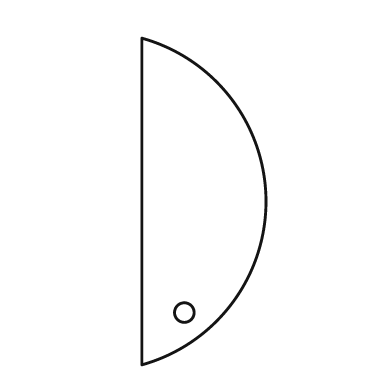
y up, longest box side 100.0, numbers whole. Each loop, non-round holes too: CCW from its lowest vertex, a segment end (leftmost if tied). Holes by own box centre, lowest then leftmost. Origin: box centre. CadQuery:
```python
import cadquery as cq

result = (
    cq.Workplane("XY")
    .moveTo(-19.0, -50.0)
    .threePointArc((19.0, 0.0), (-19.0, 50.0))
    .close()
    .moveTo(-6.0, -34.0)
    .circle(3.0)
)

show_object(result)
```